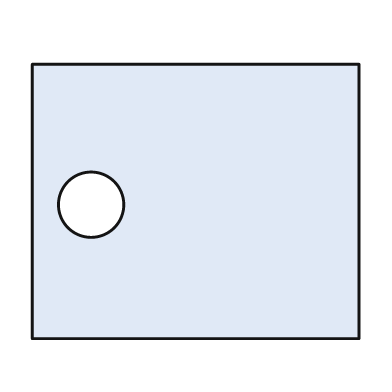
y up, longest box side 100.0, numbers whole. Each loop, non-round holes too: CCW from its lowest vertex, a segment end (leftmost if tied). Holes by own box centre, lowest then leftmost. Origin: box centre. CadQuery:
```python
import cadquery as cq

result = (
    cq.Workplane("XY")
    .moveTo(-50.0, -42.0)
    .lineTo(50.0, -42.0)
    .lineTo(50.0, 42.0)
    .lineTo(-50.0, 42.0)
    .close()
    .moveTo(-32.0, -1.0)
    .circle(10.0)
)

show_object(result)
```